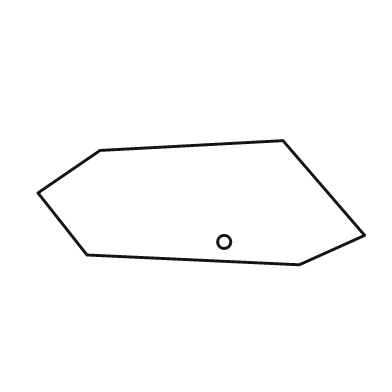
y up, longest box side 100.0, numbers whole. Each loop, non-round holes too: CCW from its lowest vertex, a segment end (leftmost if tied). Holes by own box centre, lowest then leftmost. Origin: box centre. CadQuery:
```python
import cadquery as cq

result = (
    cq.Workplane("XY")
    .moveTo(30.0, -19.0)
    .lineTo(50.0, -10.0)
    .lineTo(25.0, 19.0)
    .lineTo(-31.0, 16.0)
    .lineTo(-50.0, 3.0)
    .lineTo(-35.0, -16.0)
    .close()
    .moveTo(7.0, -12.0)
    .circle(2.0)
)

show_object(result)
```